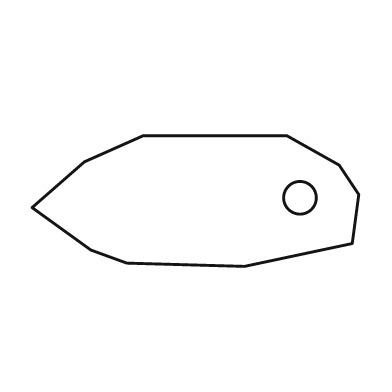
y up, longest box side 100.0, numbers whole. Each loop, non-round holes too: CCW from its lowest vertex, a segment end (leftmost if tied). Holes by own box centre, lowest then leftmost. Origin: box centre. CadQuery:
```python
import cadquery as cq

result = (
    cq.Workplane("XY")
    .moveTo(15.0, -20.0)
    .lineTo(48.0, -13.0)
    .lineTo(50.0, 2.0)
    .lineTo(44.0, 11.0)
    .lineTo(28.0, 20.0)
    .lineTo(-16.0, 20.0)
    .lineTo(-34.0, 12.0)
    .lineTo(-50.0, -2.0)
    .lineTo(-32.0, -15.0)
    .lineTo(-21.0, -19.0)
    .close()
    .moveTo(32.0, 1.0)
    .circle(5.0)
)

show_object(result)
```